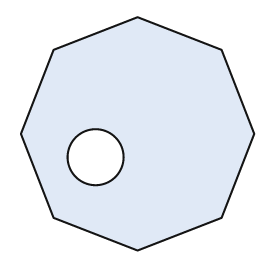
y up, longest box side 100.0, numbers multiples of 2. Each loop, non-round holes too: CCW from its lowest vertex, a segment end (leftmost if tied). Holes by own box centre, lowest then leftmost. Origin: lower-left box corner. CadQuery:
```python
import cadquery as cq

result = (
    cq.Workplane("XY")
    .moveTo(50.0, 0.0)
    .lineTo(86.0, 14.0)
    .lineTo(100.0, 50.0)
    .lineTo(86.0, 86.0)
    .lineTo(50.0, 100.0)
    .lineTo(14.0, 86.0)
    .lineTo(0.0, 50.0)
    .lineTo(14.0, 14.0)
    .close()
    .moveTo(32.0, 40.0)
    .circle(12.0)
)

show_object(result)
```